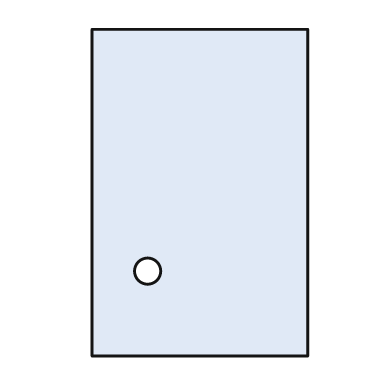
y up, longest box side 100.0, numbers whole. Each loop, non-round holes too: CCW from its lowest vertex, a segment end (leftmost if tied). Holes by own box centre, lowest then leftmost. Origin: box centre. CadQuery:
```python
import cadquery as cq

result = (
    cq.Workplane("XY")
    .moveTo(-33.0, -50.0)
    .lineTo(33.0, -50.0)
    .lineTo(33.0, 50.0)
    .lineTo(-33.0, 50.0)
    .close()
    .moveTo(-16.0, -24.0)
    .circle(4.0)
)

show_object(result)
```